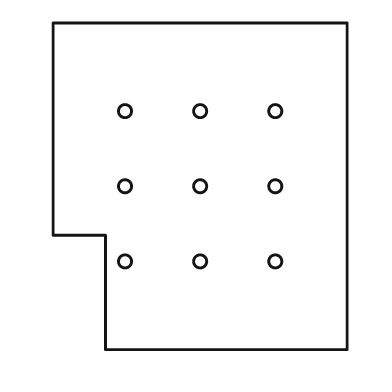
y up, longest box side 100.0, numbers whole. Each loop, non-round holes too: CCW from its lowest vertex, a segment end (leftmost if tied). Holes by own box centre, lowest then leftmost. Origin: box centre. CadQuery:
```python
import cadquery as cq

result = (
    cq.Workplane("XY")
    .moveTo(-29.0, -50.0)
    .lineTo(45.0, -50.0)
    .lineTo(45.0, 50.0)
    .lineTo(-45.0, 50.0)
    .lineTo(-45.0, -15.0)
    .lineTo(-29.0, -15.0)
    .close()
    .moveTo(-23.0, -23.0)
    .circle(2.0)
    .moveTo(0.0, -23.0)
    .circle(2.0)
    .moveTo(23.0, -23.0)
    .circle(2.0)
    .moveTo(-23.0, 0.0)
    .circle(2.0)
    .moveTo(0.0, 0.0)
    .circle(2.0)
    .moveTo(23.0, 0.0)
    .circle(2.0)
    .moveTo(-23.0, 23.0)
    .circle(2.0)
    .moveTo(0.0, 23.0)
    .circle(2.0)
    .moveTo(23.0, 23.0)
    .circle(2.0)
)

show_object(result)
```